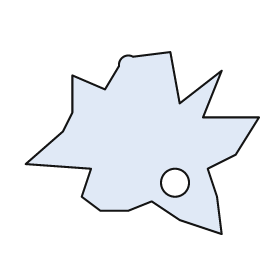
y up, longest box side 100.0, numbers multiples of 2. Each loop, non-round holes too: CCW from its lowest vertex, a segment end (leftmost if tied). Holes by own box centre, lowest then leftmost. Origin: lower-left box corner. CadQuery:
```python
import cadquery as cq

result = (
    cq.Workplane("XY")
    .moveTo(84.0, 0.0)
    .lineTo(82.0, 16.0)
    .lineTo(78.0, 28.0)
    .lineTo(90.0, 34.0)
    .lineTo(100.0, 50.0)
    .lineTo(76.0, 50.0)
    .lineTo(84.0, 70.0)
    .lineTo(66.0, 56.0)
    .lineTo(62.0, 78.0)
    .lineTo(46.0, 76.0)
    .threePointArc((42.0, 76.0), (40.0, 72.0))
    .lineTo(34.0, 62.0)
    .lineTo(20.0, 68.0)
    .lineTo(20.0, 52.0)
    .lineTo(16.0, 44.0)
    .lineTo(0.0, 30.0)
    .lineTo(28.0, 28.0)
    .lineTo(24.0, 16.0)
    .lineTo(32.0, 10.0)
    .lineTo(44.0, 10.0)
    .lineTo(54.0, 14.0)
    .lineTo(66.0, 6.0)
    .close()
    .moveTo(64.0, 22.0)
    .circle(6.0)
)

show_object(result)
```